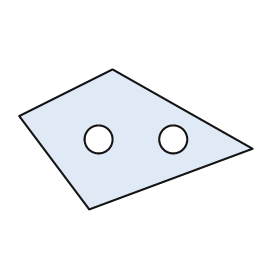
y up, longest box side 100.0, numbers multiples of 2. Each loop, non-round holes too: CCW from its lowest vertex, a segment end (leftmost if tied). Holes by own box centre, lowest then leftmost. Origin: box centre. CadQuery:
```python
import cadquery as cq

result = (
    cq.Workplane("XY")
    .moveTo(-20.0, -30.0)
    .lineTo(50.0, -4.0)
    .lineTo(-10.0, 30.0)
    .lineTo(-50.0, 10.0)
    .close()
    .moveTo(-16.0, 0.0)
    .circle(6.0)
    .moveTo(16.0, 0.0)
    .circle(6.0)
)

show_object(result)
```